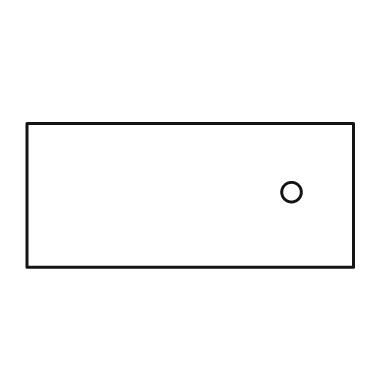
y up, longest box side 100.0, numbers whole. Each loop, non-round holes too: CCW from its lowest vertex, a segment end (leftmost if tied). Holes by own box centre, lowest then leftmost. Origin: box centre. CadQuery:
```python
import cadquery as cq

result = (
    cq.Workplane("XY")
    .moveTo(-50.0, -22.0)
    .lineTo(50.0, -22.0)
    .lineTo(50.0, 22.0)
    .lineTo(-50.0, 22.0)
    .close()
    .moveTo(31.0, 1.0)
    .circle(3.0)
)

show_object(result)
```